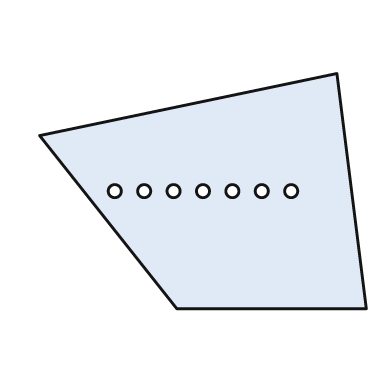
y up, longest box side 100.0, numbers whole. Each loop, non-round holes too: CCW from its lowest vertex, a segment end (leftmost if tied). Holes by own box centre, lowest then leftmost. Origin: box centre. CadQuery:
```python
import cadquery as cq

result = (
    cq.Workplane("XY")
    .moveTo(-8.0, -36.0)
    .lineTo(50.0, -36.0)
    .lineTo(41.0, 36.0)
    .lineTo(-50.0, 17.0)
    .close()
    .moveTo(-27.0, 0.0)
    .circle(2.0)
    .moveTo(-18.0, 0.0)
    .circle(2.0)
    .moveTo(-9.0, 0.0)
    .circle(2.0)
    .moveTo(0.0, 0.0)
    .circle(2.0)
    .moveTo(9.0, 0.0)
    .circle(2.0)
    .moveTo(18.0, 0.0)
    .circle(2.0)
    .moveTo(27.0, 0.0)
    .circle(2.0)
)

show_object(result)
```